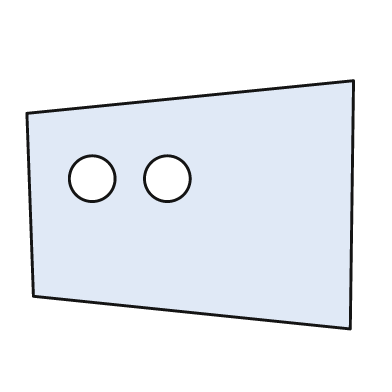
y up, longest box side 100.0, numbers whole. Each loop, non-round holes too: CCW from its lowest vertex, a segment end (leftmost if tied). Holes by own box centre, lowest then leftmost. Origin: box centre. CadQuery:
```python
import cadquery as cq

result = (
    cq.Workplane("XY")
    .moveTo(49.0, -38.0)
    .lineTo(50.0, 38.0)
    .lineTo(-50.0, 28.0)
    .lineTo(-48.0, -28.0)
    .close()
    .moveTo(-30.0, 8.0)
    .circle(7.0)
    .moveTo(-7.0, 8.0)
    .circle(7.0)
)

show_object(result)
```